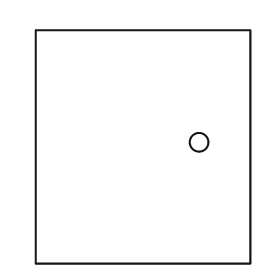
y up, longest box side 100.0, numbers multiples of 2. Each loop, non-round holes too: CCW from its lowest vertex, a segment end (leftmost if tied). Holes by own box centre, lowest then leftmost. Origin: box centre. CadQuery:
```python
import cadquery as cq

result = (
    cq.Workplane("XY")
    .moveTo(-46.0, -50.0)
    .lineTo(46.0, -50.0)
    .lineTo(46.0, 50.0)
    .lineTo(-46.0, 50.0)
    .close()
    .moveTo(24.0, 2.0)
    .circle(4.0)
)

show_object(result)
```